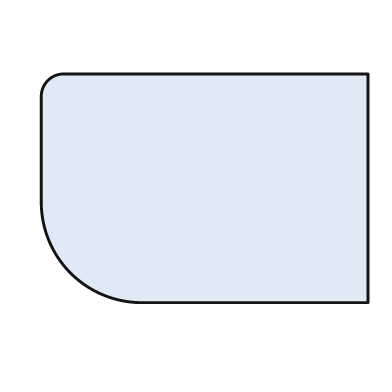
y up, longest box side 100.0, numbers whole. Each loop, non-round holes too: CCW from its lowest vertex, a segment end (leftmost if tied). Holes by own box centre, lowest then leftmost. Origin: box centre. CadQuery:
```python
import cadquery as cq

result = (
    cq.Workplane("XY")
    .moveTo(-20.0, -35.0)
    .lineTo(50.0, -35.0)
    .lineTo(50.0, 35.0)
    .lineTo(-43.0, 35.0)
    .threePointArc((-48.0, 33.0), (-50.0, 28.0))
    .lineTo(-50.0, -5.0)
    .threePointArc((-41.0, -26.0), (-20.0, -35.0))
    .close()
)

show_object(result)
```